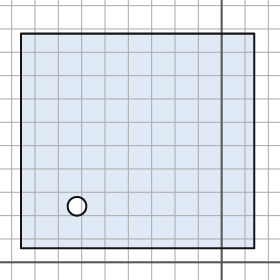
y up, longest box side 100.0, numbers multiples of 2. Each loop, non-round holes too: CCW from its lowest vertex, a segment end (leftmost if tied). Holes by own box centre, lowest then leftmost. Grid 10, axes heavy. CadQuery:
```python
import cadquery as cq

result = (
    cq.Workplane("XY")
    .moveTo(-86.0, 6.0)
    .lineTo(14.0, 6.0)
    .lineTo(14.0, 98.0)
    .lineTo(-86.0, 98.0)
    .close()
    .moveTo(-62.0, 24.0)
    .circle(4.0)
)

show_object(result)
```